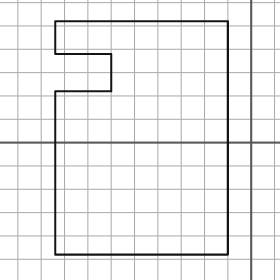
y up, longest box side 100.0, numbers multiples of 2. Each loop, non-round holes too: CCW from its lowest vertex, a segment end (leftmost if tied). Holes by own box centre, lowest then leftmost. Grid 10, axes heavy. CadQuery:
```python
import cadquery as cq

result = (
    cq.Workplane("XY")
    .moveTo(-84.0, -48.0)
    .lineTo(-10.0, -48.0)
    .lineTo(-10.0, 52.0)
    .lineTo(-84.0, 52.0)
    .lineTo(-84.0, 38.0)
    .lineTo(-60.0, 38.0)
    .lineTo(-60.0, 22.0)
    .lineTo(-84.0, 22.0)
    .close()
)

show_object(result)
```